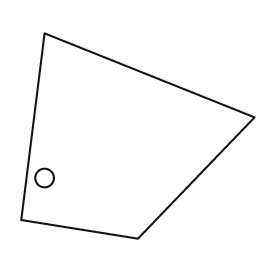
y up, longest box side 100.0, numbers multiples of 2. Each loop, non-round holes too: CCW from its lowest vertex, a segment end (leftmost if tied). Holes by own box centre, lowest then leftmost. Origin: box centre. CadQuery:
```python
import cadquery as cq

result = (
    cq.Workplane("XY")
    .moveTo(0.0, -44.0)
    .lineTo(50.0, 8.0)
    .lineTo(-40.0, 44.0)
    .lineTo(-50.0, -36.0)
    .close()
    .moveTo(-40.0, -18.0)
    .circle(4.0)
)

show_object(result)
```